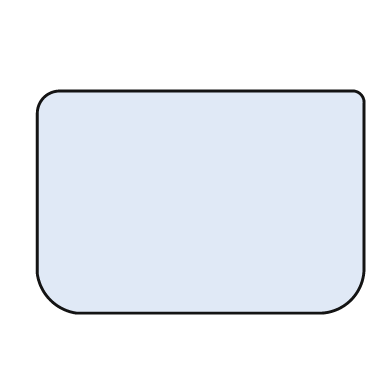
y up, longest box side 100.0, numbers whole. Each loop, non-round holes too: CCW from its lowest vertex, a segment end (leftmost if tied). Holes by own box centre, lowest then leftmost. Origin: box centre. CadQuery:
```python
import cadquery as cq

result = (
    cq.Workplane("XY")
    .moveTo(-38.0, -34.0)
    .lineTo(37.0, -34.0)
    .threePointArc((46.0, -30.0), (50.0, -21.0))
    .lineTo(50.0, 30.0)
    .threePointArc((49.0, 33.0), (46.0, 34.0))
    .lineTo(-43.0, 34.0)
    .threePointArc((-48.0, 32.0), (-50.0, 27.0))
    .lineTo(-50.0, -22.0)
    .threePointArc((-46.0, -30.0), (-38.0, -34.0))
    .close()
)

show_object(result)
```